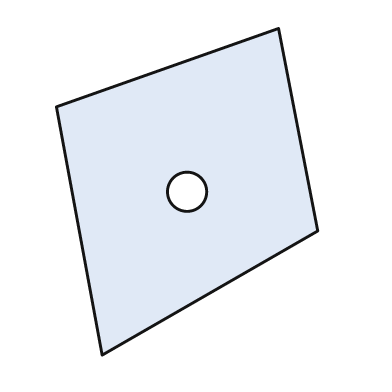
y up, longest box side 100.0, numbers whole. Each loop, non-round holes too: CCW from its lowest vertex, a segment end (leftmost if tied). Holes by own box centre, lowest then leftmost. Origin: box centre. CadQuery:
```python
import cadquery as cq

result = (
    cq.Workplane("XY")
    .moveTo(-26.0, -50.0)
    .lineTo(40.0, -12.0)
    .lineTo(28.0, 50.0)
    .lineTo(-40.0, 26.0)
    .close()
    .moveTo(0.0, 0.0)
    .circle(6.0)
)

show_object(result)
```